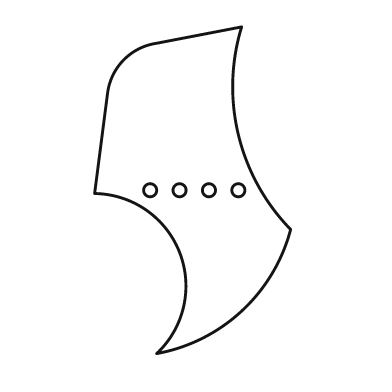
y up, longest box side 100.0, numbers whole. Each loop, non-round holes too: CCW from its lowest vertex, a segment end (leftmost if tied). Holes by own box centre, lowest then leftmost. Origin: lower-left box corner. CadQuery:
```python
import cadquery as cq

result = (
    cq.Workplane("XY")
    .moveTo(19.0, 0.0)
    .threePointArc((45.0, 13.0), (60.0, 38.0))
    .threePointArc((44.0, 67.0), (45.0, 100.0))
    .lineTo(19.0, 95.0)
    .threePointArc((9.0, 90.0), (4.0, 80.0))
    .lineTo(0.0, 49.0)
    .threePointArc((26.0, 31.0), (19.0, 0.0))
    .close()
    .moveTo(17.0, 50.0)
    .circle(2.0)
    .moveTo(26.0, 50.0)
    .circle(2.0)
    .moveTo(35.0, 50.0)
    .circle(2.0)
    .moveTo(44.0, 50.0)
    .circle(2.0)
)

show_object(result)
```